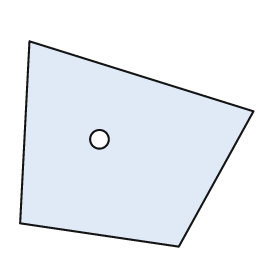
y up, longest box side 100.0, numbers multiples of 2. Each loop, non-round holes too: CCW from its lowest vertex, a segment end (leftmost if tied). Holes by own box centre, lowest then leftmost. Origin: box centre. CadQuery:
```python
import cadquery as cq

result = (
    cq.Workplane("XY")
    .moveTo(18.0, -44.0)
    .lineTo(50.0, 14.0)
    .lineTo(-46.0, 44.0)
    .lineTo(-50.0, -34.0)
    .close()
    .moveTo(-16.0, 2.0)
    .circle(4.0)
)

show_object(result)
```